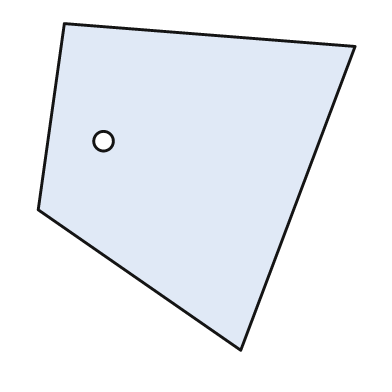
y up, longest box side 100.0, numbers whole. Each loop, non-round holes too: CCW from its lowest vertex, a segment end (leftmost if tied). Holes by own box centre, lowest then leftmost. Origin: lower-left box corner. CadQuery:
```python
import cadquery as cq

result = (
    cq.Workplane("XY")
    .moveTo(62.0, 0.0)
    .lineTo(97.0, 93.0)
    .lineTo(8.0, 100.0)
    .lineTo(0.0, 43.0)
    .close()
    .moveTo(20.0, 64.0)
    .circle(3.0)
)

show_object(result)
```